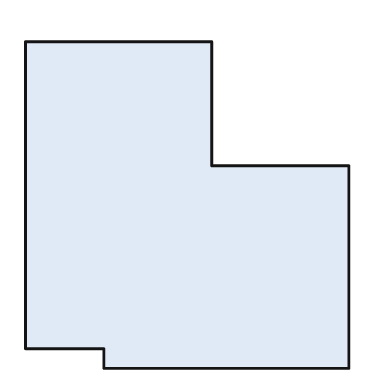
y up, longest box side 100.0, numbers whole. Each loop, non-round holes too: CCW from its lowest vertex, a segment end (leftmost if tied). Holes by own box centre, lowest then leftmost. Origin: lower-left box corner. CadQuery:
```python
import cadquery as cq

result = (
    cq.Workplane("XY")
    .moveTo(24.0, 0.0)
    .lineTo(99.0, 0.0)
    .lineTo(99.0, 62.0)
    .lineTo(57.0, 62.0)
    .lineTo(57.0, 100.0)
    .lineTo(0.0, 100.0)
    .lineTo(0.0, 6.0)
    .lineTo(24.0, 6.0)
    .close()
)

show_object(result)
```